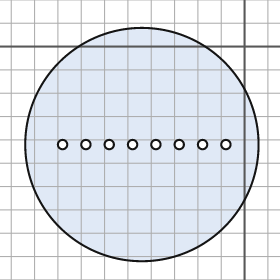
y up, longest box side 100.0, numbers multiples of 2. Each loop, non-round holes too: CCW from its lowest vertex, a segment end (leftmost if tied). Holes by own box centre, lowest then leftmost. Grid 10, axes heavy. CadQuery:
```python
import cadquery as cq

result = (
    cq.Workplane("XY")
    .moveTo(-44.0, -42.0)
    .circle(50.0)
    .moveTo(-78.0, -42.0)
    .circle(2.0)
    .moveTo(-68.0, -42.0)
    .circle(2.0)
    .moveTo(-58.0, -42.0)
    .circle(2.0)
    .moveTo(-48.0, -42.0)
    .circle(2.0)
    .moveTo(-38.0, -42.0)
    .circle(2.0)
    .moveTo(-28.0, -42.0)
    .circle(2.0)
    .moveTo(-18.0, -42.0)
    .circle(2.0)
    .moveTo(-8.0, -42.0)
    .circle(2.0)
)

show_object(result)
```